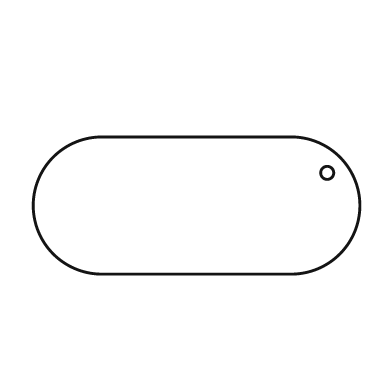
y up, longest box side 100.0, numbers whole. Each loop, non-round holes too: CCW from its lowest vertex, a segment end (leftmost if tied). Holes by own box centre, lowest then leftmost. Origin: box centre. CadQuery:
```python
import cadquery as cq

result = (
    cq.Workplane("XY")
    .moveTo(-29.0, -21.0)
    .lineTo(29.0, -21.0)
    .threePointArc((50.0, 0.0), (29.0, 21.0))
    .lineTo(-29.0, 21.0)
    .threePointArc((-50.0, 0.0), (-29.0, -21.0))
    .close()
    .moveTo(40.0, 10.0)
    .circle(2.0)
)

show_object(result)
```